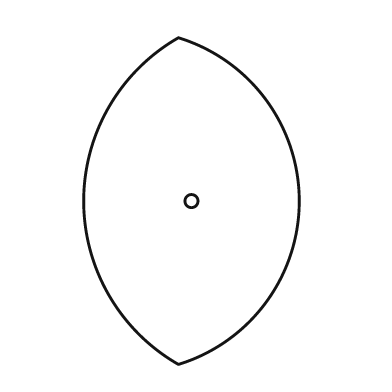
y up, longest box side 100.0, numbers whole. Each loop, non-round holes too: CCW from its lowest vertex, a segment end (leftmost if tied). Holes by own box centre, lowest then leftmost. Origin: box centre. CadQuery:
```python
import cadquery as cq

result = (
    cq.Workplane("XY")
    .moveTo(-4.0, -50.0)
    .threePointArc((33.0, 0.0), (-4.0, 50.0))
    .threePointArc((-33.0, 0.0), (-4.0, -50.0))
    .close()
    .moveTo(0.0, 0.0)
    .circle(2.0)
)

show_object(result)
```